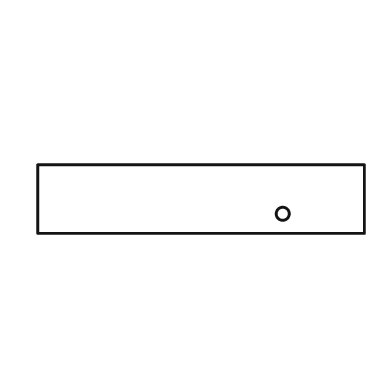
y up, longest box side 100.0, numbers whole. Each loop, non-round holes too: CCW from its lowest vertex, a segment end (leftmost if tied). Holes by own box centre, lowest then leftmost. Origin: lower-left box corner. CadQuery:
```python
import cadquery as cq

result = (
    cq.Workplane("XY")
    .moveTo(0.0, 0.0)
    .lineTo(100.0, 0.0)
    .lineTo(100.0, 21.0)
    .lineTo(0.0, 21.0)
    .close()
    .moveTo(75.0, 6.0)
    .circle(2.0)
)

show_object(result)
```